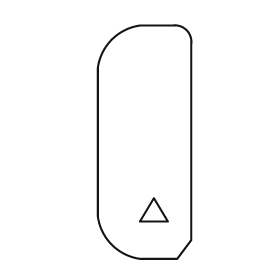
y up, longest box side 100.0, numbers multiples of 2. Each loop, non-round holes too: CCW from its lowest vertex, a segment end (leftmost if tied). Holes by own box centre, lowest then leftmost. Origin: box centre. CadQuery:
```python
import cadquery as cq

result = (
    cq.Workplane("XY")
    .moveTo(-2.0, -50.0)
    .lineTo(14.0, -50.0)
    .lineTo(20.0, -42.0)
    .lineTo(20.0, 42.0)
    .threePointArc((18.0, 48.0), (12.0, 50.0))
    .lineTo(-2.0, 50.0)
    .threePointArc((-14.0, 44.0), (-20.0, 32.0))
    .lineTo(-20.0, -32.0)
    .threePointArc((-14.0, -44.0), (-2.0, -50.0))
    .close()
    .moveTo(-2.0, -34.0)
    .lineTo(10.0, -34.0)
    .lineTo(4.0, -24.0)
    .close()
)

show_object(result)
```